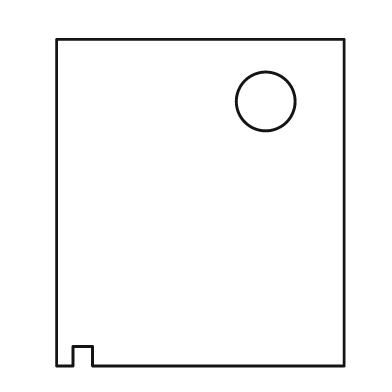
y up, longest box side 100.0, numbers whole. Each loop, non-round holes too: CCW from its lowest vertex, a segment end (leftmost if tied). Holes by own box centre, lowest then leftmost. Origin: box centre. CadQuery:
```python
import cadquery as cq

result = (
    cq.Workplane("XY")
    .moveTo(-44.0, -50.0)
    .lineTo(-39.0, -50.0)
    .lineTo(-39.0, -44.0)
    .lineTo(-33.0, -44.0)
    .lineTo(-33.0, -50.0)
    .lineTo(44.0, -50.0)
    .lineTo(44.0, 50.0)
    .lineTo(-44.0, 50.0)
    .close()
    .moveTo(20.0, 31.0)
    .circle(9.0)
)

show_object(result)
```